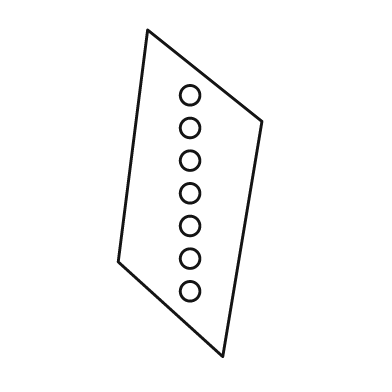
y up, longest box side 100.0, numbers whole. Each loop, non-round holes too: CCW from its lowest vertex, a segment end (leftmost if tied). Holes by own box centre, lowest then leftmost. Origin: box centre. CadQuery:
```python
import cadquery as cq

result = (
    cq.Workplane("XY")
    .moveTo(10.0, -50.0)
    .lineTo(22.0, 22.0)
    .lineTo(-13.0, 50.0)
    .lineTo(-22.0, -21.0)
    .close()
    .moveTo(0.0, -30.0)
    .circle(3.0)
    .moveTo(0.0, -20.0)
    .circle(3.0)
    .moveTo(0.0, -10.0)
    .circle(3.0)
    .moveTo(0.0, 0.0)
    .circle(3.0)
    .moveTo(0.0, 10.0)
    .circle(3.0)
    .moveTo(0.0, 20.0)
    .circle(3.0)
    .moveTo(0.0, 30.0)
    .circle(3.0)
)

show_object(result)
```